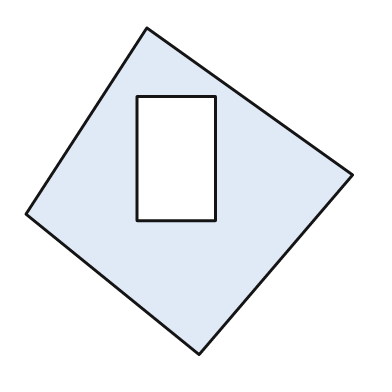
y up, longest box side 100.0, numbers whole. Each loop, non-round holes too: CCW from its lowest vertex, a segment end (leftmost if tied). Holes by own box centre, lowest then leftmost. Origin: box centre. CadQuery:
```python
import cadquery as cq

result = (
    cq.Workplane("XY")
    .moveTo(3.0, -50.0)
    .lineTo(50.0, 5.0)
    .lineTo(-13.0, 50.0)
    .lineTo(-50.0, -7.0)
    .close()
    .moveTo(-16.0, -9.0)
    .lineTo(8.0, -9.0)
    .lineTo(8.0, 29.0)
    .lineTo(-16.0, 29.0)
    .close()
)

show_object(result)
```